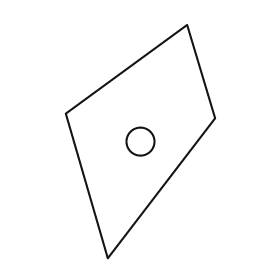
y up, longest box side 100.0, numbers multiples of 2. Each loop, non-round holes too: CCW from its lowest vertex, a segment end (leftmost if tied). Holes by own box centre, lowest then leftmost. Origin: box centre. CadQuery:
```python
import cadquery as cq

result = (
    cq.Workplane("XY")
    .moveTo(-14.0, -50.0)
    .lineTo(32.0, 10.0)
    .lineTo(20.0, 50.0)
    .lineTo(-32.0, 12.0)
    .close()
    .moveTo(0.0, 0.0)
    .circle(6.0)
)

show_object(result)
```